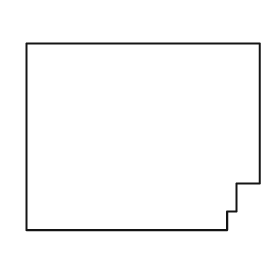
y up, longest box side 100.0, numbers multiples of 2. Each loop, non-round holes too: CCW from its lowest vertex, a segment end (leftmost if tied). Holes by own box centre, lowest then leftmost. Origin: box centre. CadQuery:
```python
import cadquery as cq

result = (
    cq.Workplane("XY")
    .moveTo(-50.0, -40.0)
    .lineTo(36.0, -40.0)
    .lineTo(36.0, -32.0)
    .lineTo(40.0, -32.0)
    .lineTo(40.0, -20.0)
    .lineTo(50.0, -20.0)
    .lineTo(50.0, 40.0)
    .lineTo(-50.0, 40.0)
    .close()
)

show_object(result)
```